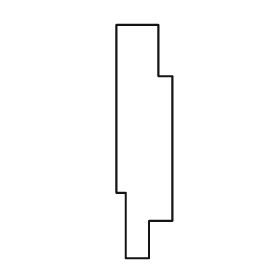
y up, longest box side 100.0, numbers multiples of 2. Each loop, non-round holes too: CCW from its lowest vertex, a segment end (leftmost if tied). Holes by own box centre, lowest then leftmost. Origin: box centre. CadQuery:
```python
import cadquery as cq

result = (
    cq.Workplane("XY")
    .moveTo(-8.0, -50.0)
    .lineTo(2.0, -50.0)
    .lineTo(2.0, -34.0)
    .lineTo(12.0, -34.0)
    .lineTo(12.0, 28.0)
    .lineTo(6.0, 28.0)
    .lineTo(6.0, 50.0)
    .lineTo(-12.0, 50.0)
    .lineTo(-12.0, -22.0)
    .lineTo(-8.0, -22.0)
    .close()
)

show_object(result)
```